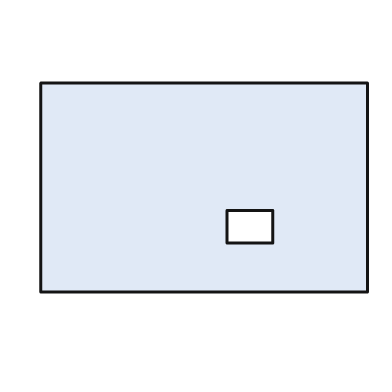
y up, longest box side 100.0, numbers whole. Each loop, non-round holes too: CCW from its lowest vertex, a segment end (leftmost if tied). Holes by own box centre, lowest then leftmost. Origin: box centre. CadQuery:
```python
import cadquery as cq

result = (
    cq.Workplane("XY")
    .moveTo(-50.0, -32.0)
    .lineTo(50.0, -32.0)
    .lineTo(50.0, 32.0)
    .lineTo(-50.0, 32.0)
    .close()
    .moveTo(7.0, -17.0)
    .lineTo(21.0, -17.0)
    .lineTo(21.0, -7.0)
    .lineTo(7.0, -7.0)
    .close()
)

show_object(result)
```